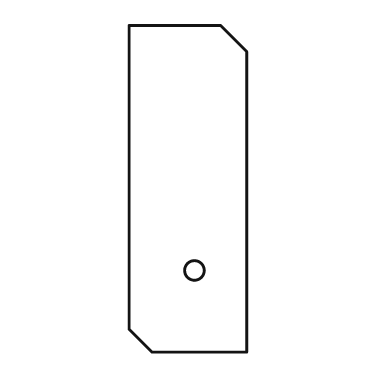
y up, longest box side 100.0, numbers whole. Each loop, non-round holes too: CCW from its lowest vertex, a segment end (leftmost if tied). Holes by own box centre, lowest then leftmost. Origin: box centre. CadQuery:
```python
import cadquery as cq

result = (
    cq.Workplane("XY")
    .moveTo(-11.0, -50.0)
    .lineTo(18.0, -50.0)
    .lineTo(18.0, 42.0)
    .lineTo(10.0, 50.0)
    .lineTo(-18.0, 50.0)
    .lineTo(-18.0, -43.0)
    .close()
    .moveTo(2.0, -25.0)
    .circle(3.0)
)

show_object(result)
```